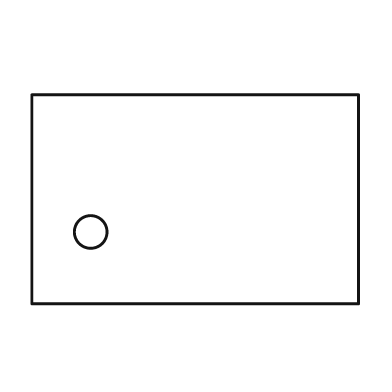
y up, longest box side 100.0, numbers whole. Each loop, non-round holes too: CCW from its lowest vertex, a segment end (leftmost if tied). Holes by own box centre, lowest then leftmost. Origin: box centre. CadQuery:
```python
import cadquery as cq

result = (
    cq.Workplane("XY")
    .moveTo(-50.0, -32.0)
    .lineTo(50.0, -32.0)
    .lineTo(50.0, 32.0)
    .lineTo(-50.0, 32.0)
    .close()
    .moveTo(-32.0, -10.0)
    .circle(5.0)
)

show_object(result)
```